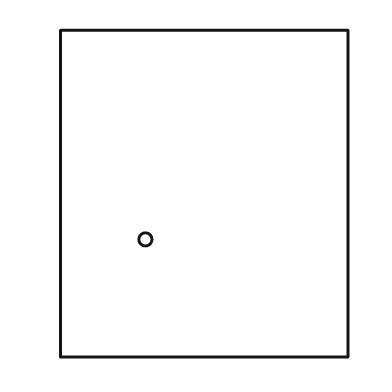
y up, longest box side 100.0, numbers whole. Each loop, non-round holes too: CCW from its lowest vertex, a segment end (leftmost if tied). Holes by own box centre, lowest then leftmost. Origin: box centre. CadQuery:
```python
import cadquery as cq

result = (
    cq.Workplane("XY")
    .moveTo(-44.0, -50.0)
    .lineTo(44.0, -50.0)
    .lineTo(44.0, 50.0)
    .lineTo(-44.0, 50.0)
    .close()
    .moveTo(-18.0, -14.0)
    .circle(2.0)
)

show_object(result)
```